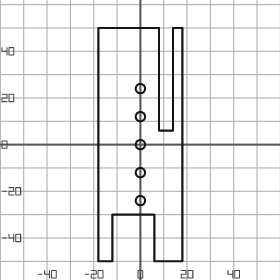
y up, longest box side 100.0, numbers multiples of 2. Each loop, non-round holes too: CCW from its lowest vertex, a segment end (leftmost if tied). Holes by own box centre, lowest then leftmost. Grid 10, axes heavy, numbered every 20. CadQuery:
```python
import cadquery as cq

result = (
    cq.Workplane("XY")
    .moveTo(-18.0, -50.0)
    .lineTo(-12.0, -50.0)
    .lineTo(-12.0, -30.0)
    .lineTo(6.0, -30.0)
    .lineTo(6.0, -50.0)
    .lineTo(18.0, -50.0)
    .lineTo(18.0, 50.0)
    .lineTo(14.0, 50.0)
    .lineTo(14.0, 6.0)
    .lineTo(8.0, 6.0)
    .lineTo(8.0, 50.0)
    .lineTo(-18.0, 50.0)
    .close()
    .moveTo(0.0, -24.0)
    .circle(2.0)
    .moveTo(0.0, -12.0)
    .circle(2.0)
    .moveTo(0.0, 0.0)
    .circle(2.0)
    .moveTo(0.0, 12.0)
    .circle(2.0)
    .moveTo(0.0, 24.0)
    .circle(2.0)
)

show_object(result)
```